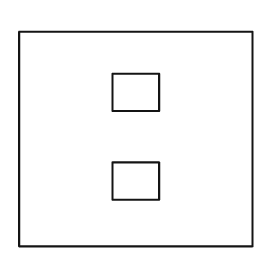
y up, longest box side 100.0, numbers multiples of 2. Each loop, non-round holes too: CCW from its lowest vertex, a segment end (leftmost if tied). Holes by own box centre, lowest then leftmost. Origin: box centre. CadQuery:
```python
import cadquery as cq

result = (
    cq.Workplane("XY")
    .moveTo(-50.0, -46.0)
    .lineTo(50.0, -46.0)
    .lineTo(50.0, 46.0)
    .lineTo(-50.0, 46.0)
    .close()
    .moveTo(-10.0, -26.0)
    .lineTo(10.0, -26.0)
    .lineTo(10.0, -10.0)
    .lineTo(-10.0, -10.0)
    .close()
    .moveTo(-10.0, 12.0)
    .lineTo(10.0, 12.0)
    .lineTo(10.0, 28.0)
    .lineTo(-10.0, 28.0)
    .close()
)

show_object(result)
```